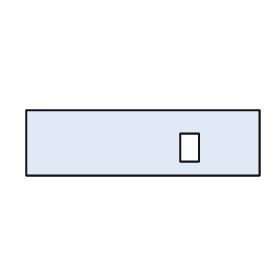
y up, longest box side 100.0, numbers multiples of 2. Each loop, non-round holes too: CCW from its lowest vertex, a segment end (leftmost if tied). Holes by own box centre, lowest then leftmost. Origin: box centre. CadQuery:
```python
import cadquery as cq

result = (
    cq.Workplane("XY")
    .moveTo(-50.0, -14.0)
    .lineTo(50.0, -14.0)
    .lineTo(50.0, 14.0)
    .lineTo(-50.0, 14.0)
    .close()
    .moveTo(16.0, -8.0)
    .lineTo(24.0, -8.0)
    .lineTo(24.0, 4.0)
    .lineTo(16.0, 4.0)
    .close()
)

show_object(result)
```